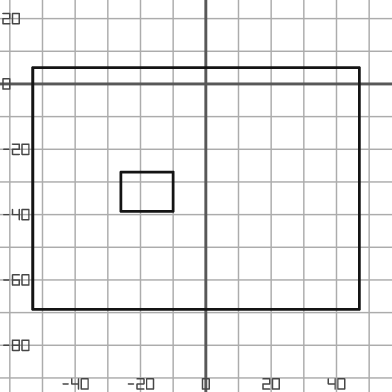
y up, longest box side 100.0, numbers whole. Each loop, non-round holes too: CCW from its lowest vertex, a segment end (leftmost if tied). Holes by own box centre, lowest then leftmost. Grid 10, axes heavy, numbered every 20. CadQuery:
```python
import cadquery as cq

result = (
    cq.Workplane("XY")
    .moveTo(-53.0, -69.0)
    .lineTo(47.0, -69.0)
    .lineTo(47.0, 5.0)
    .lineTo(-53.0, 5.0)
    .close()
    .moveTo(-26.0, -39.0)
    .lineTo(-10.0, -39.0)
    .lineTo(-10.0, -27.0)
    .lineTo(-26.0, -27.0)
    .close()
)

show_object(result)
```